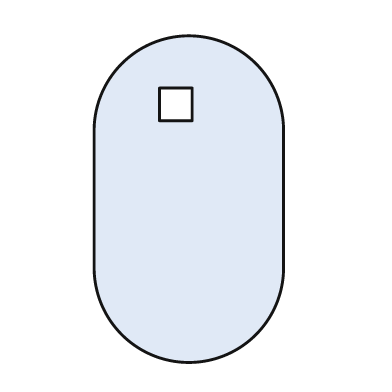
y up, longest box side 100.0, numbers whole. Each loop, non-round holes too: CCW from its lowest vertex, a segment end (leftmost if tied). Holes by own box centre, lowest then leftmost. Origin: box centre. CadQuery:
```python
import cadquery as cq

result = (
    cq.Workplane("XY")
    .moveTo(-29.0, -21.0)
    .threePointArc((0.0, -50.0), (29.0, -21.0))
    .lineTo(29.0, 21.0)
    .threePointArc((0.0, 50.0), (-29.0, 21.0))
    .close()
    .moveTo(-9.0, 24.0)
    .lineTo(1.0, 24.0)
    .lineTo(1.0, 34.0)
    .lineTo(-9.0, 34.0)
    .close()
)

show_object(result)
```